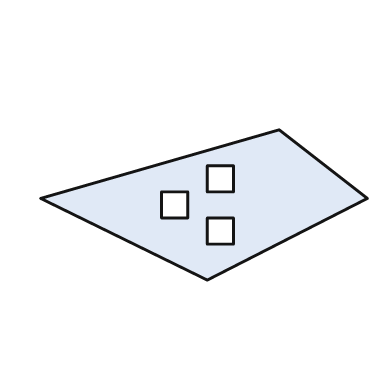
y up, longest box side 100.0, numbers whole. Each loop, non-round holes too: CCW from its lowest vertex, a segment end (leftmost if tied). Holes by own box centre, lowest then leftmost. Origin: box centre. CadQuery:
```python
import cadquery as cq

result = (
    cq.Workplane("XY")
    .moveTo(1.0, -23.0)
    .lineTo(50.0, 2.0)
    .lineTo(23.0, 23.0)
    .lineTo(-50.0, 2.0)
    .close()
    .moveTo(1.0, -12.0)
    .lineTo(9.0, -12.0)
    .lineTo(9.0, -4.0)
    .lineTo(1.0, -4.0)
    .close()
    .moveTo(-13.0, -4.0)
    .lineTo(-5.0, -4.0)
    .lineTo(-5.0, 4.0)
    .lineTo(-13.0, 4.0)
    .close()
    .moveTo(1.0, 4.0)
    .lineTo(9.0, 4.0)
    .lineTo(9.0, 12.0)
    .lineTo(1.0, 12.0)
    .close()
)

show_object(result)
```